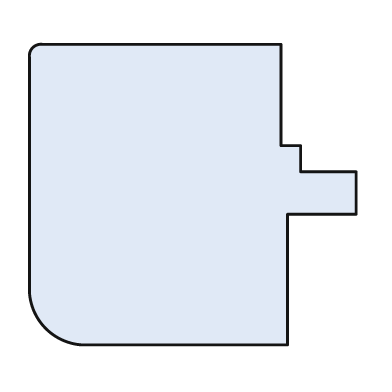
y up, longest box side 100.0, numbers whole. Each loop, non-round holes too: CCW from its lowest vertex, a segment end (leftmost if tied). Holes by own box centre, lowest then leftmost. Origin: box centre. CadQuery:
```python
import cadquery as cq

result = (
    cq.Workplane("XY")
    .moveTo(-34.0, -46.0)
    .lineTo(29.0, -46.0)
    .lineTo(29.0, -6.0)
    .lineTo(50.0, -6.0)
    .lineTo(50.0, 7.0)
    .lineTo(33.0, 7.0)
    .lineTo(33.0, 15.0)
    .lineTo(27.0, 15.0)
    .lineTo(27.0, 46.0)
    .lineTo(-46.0, 46.0)
    .threePointArc((-49.0, 45.0), (-50.0, 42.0))
    .lineTo(-50.0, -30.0)
    .threePointArc((-45.0, -41.0), (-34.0, -46.0))
    .close()
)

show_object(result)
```